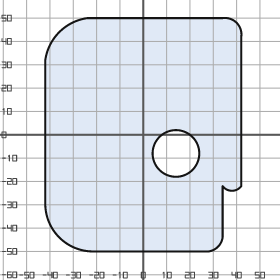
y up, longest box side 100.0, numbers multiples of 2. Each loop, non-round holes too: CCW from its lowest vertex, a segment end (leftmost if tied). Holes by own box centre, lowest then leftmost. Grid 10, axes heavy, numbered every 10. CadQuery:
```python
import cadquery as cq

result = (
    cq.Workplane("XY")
    .moveTo(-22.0, -50.0)
    .lineTo(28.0, -50.0)
    .threePointArc((32.0, -48.0), (34.0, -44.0))
    .lineTo(34.0, -22.0)
    .threePointArc((38.0, -24.0), (42.0, -22.0))
    .lineTo(42.0, 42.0)
    .threePointArc((40.0, 48.0), (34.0, 50.0))
    .lineTo(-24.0, 50.0)
    .threePointArc((-36.0, 44.0), (-42.0, 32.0))
    .lineTo(-42.0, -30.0)
    .threePointArc((-36.0, -44.0), (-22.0, -50.0))
    .close()
    .moveTo(14.0, -8.0)
    .circle(10.0)
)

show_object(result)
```